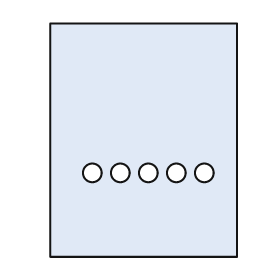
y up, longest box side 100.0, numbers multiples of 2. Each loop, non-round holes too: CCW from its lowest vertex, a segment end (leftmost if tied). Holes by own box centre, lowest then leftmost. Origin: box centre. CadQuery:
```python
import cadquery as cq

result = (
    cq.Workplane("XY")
    .moveTo(-40.0, -50.0)
    .lineTo(40.0, -50.0)
    .lineTo(40.0, 50.0)
    .lineTo(-40.0, 50.0)
    .close()
    .moveTo(-22.0, -14.0)
    .circle(4.0)
    .moveTo(-10.0, -14.0)
    .circle(4.0)
    .moveTo(2.0, -14.0)
    .circle(4.0)
    .moveTo(14.0, -14.0)
    .circle(4.0)
    .moveTo(26.0, -14.0)
    .circle(4.0)
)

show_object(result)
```